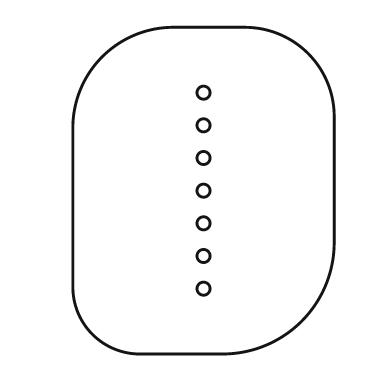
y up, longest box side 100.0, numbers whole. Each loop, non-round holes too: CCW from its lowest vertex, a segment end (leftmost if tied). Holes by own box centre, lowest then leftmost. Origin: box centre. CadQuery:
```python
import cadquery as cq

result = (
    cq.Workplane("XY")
    .moveTo(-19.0, -50.0)
    .lineTo(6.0, -50.0)
    .threePointArc((30.0, -40.0), (40.0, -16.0))
    .lineTo(40.0, 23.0)
    .threePointArc((32.0, 42.0), (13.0, 50.0))
    .lineTo(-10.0, 50.0)
    .threePointArc((-31.0, 41.0), (-40.0, 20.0))
    .lineTo(-40.0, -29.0)
    .threePointArc((-34.0, -44.0), (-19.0, -50.0))
    .close()
    .moveTo(0.0, -30.0)
    .circle(2.0)
    .moveTo(0.0, -20.0)
    .circle(2.0)
    .moveTo(0.0, -10.0)
    .circle(2.0)
    .moveTo(0.0, 0.0)
    .circle(2.0)
    .moveTo(0.0, 10.0)
    .circle(2.0)
    .moveTo(0.0, 20.0)
    .circle(2.0)
    .moveTo(0.0, 30.0)
    .circle(2.0)
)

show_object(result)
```